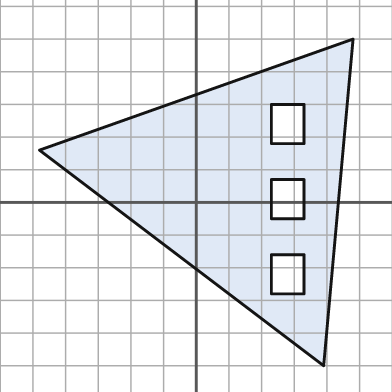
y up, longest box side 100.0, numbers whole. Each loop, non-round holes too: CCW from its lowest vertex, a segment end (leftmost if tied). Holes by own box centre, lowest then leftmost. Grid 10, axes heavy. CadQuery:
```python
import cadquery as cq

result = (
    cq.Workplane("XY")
    .moveTo(39.0, -50.0)
    .lineTo(48.0, 50.0)
    .lineTo(-48.0, 16.0)
    .close()
    .moveTo(23.0, -28.0)
    .lineTo(33.0, -28.0)
    .lineTo(33.0, -16.0)
    .lineTo(23.0, -16.0)
    .close()
    .moveTo(23.0, -5.0)
    .lineTo(33.0, -5.0)
    .lineTo(33.0, 7.0)
    .lineTo(23.0, 7.0)
    .close()
    .moveTo(23.0, 18.0)
    .lineTo(33.0, 18.0)
    .lineTo(33.0, 30.0)
    .lineTo(23.0, 30.0)
    .close()
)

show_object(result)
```